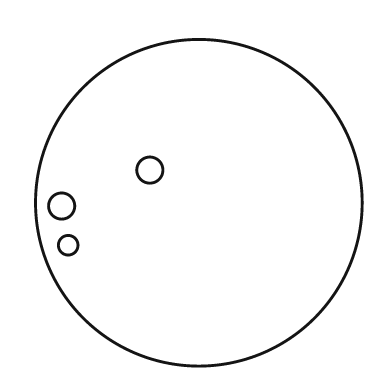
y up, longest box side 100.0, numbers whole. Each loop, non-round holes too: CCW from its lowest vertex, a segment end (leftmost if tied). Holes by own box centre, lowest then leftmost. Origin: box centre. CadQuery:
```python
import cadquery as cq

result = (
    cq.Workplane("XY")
    .moveTo(0.0, 0.0)
    .circle(50.0)
    .moveTo(-40.0, -13.0)
    .circle(3.0)
    .moveTo(-42.0, -1.0)
    .circle(4.0)
    .moveTo(-15.0, 10.0)
    .circle(4.0)
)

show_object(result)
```